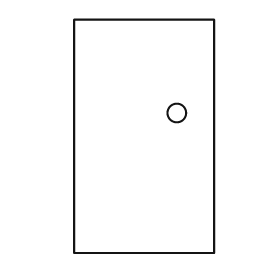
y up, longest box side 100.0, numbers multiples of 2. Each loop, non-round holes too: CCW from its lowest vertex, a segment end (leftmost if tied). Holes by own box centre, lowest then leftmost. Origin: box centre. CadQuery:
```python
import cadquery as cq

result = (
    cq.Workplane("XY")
    .moveTo(-30.0, -50.0)
    .lineTo(30.0, -50.0)
    .lineTo(30.0, 50.0)
    .lineTo(-30.0, 50.0)
    .close()
    .moveTo(14.0, 10.0)
    .circle(4.0)
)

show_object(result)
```